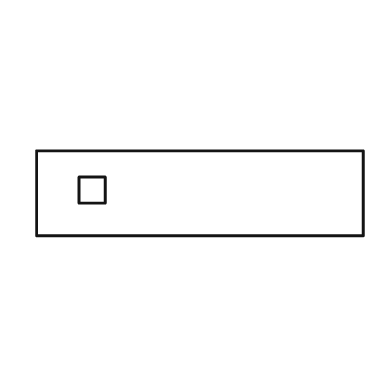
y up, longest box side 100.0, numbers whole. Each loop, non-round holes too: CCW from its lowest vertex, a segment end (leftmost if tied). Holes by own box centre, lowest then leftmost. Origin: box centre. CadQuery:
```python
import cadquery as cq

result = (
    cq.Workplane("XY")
    .moveTo(-50.0, -13.0)
    .lineTo(50.0, -13.0)
    .lineTo(50.0, 13.0)
    .lineTo(-50.0, 13.0)
    .close()
    .moveTo(-37.0, -3.0)
    .lineTo(-29.0, -3.0)
    .lineTo(-29.0, 5.0)
    .lineTo(-37.0, 5.0)
    .close()
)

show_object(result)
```